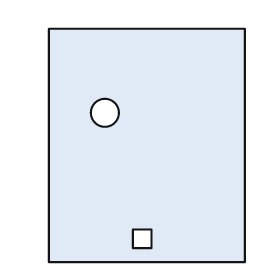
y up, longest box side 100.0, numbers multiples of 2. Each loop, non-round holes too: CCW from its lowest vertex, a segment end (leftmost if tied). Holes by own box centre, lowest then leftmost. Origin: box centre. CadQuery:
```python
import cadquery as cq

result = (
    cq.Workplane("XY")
    .moveTo(-42.0, -50.0)
    .lineTo(42.0, -50.0)
    .lineTo(42.0, 50.0)
    .lineTo(-42.0, 50.0)
    .close()
    .moveTo(-6.0, -44.0)
    .lineTo(2.0, -44.0)
    .lineTo(2.0, -36.0)
    .lineTo(-6.0, -36.0)
    .close()
    .moveTo(-18.0, 14.0)
    .circle(6.0)
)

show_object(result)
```